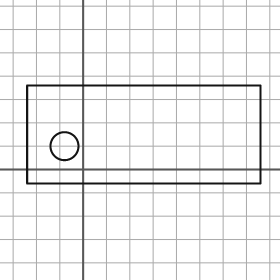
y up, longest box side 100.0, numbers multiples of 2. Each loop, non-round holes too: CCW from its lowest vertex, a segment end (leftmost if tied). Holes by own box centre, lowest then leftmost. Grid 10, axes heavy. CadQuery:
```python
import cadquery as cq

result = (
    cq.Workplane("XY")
    .moveTo(-24.0, -6.0)
    .lineTo(76.0, -6.0)
    .lineTo(76.0, 36.0)
    .lineTo(-24.0, 36.0)
    .close()
    .moveTo(-8.0, 10.0)
    .circle(6.0)
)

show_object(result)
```